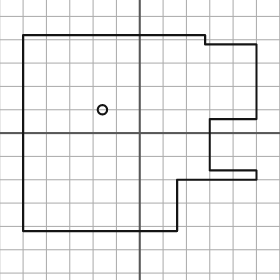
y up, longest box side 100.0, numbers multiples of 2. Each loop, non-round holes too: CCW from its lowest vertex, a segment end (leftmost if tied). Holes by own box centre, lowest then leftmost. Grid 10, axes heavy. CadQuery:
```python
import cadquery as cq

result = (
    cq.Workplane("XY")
    .moveTo(-50.0, -42.0)
    .lineTo(16.0, -42.0)
    .lineTo(16.0, -20.0)
    .lineTo(50.0, -20.0)
    .lineTo(50.0, -16.0)
    .lineTo(30.0, -16.0)
    .lineTo(30.0, 6.0)
    .lineTo(50.0, 6.0)
    .lineTo(50.0, 38.0)
    .lineTo(28.0, 38.0)
    .lineTo(28.0, 42.0)
    .lineTo(-50.0, 42.0)
    .close()
    .moveTo(-16.0, 10.0)
    .circle(2.0)
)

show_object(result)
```